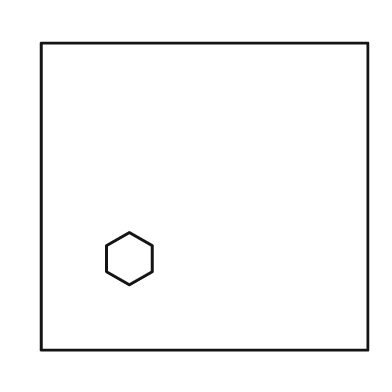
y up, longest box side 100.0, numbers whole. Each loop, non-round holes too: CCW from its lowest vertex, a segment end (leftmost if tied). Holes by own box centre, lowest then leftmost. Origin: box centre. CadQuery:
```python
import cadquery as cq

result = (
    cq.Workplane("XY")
    .moveTo(-50.0, -47.0)
    .lineTo(50.0, -47.0)
    .lineTo(50.0, 47.0)
    .lineTo(-50.0, 47.0)
    .close()
    .moveTo(-23.0, -27.0)
    .lineTo(-16.0, -23.0)
    .lineTo(-16.0, -15.0)
    .lineTo(-23.0, -11.0)
    .lineTo(-30.0, -15.0)
    .lineTo(-30.0, -23.0)
    .close()
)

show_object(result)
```